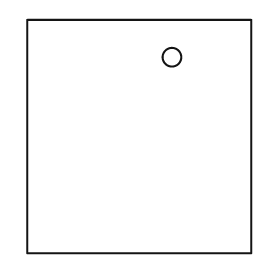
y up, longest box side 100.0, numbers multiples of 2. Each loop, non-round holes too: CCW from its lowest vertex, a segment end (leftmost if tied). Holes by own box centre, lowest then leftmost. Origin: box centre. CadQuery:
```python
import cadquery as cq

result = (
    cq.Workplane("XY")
    .moveTo(-48.0, -50.0)
    .lineTo(48.0, -50.0)
    .lineTo(48.0, 50.0)
    .lineTo(-48.0, 50.0)
    .close()
    .moveTo(14.0, 34.0)
    .circle(4.0)
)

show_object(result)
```